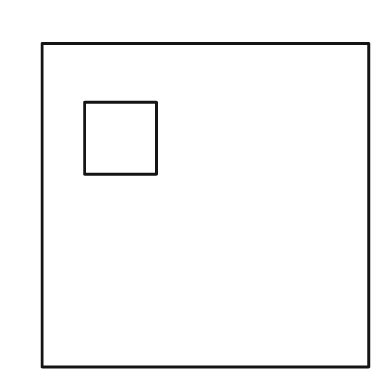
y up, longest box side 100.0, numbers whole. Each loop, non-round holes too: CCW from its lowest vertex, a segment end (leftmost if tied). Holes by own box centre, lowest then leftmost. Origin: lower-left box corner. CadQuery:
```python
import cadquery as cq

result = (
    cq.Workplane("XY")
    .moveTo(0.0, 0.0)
    .lineTo(100.0, 0.0)
    .lineTo(100.0, 99.0)
    .lineTo(0.0, 99.0)
    .close()
    .moveTo(13.0, 59.0)
    .lineTo(35.0, 59.0)
    .lineTo(35.0, 81.0)
    .lineTo(13.0, 81.0)
    .close()
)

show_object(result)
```